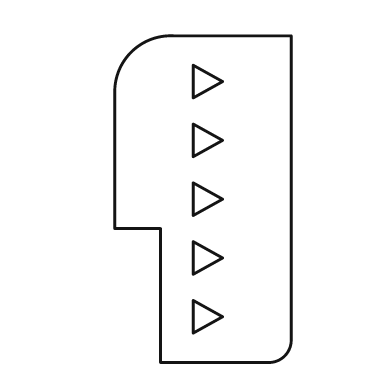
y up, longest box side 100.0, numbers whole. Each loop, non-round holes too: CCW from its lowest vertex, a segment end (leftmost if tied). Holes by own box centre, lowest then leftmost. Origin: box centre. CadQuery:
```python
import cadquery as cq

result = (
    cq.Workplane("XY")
    .moveTo(-13.0, -50.0)
    .lineTo(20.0, -50.0)
    .threePointArc((25.0, -48.0), (27.0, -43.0))
    .lineTo(27.0, 50.0)
    .lineTo(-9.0, 50.0)
    .threePointArc((-22.0, 45.0), (-27.0, 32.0))
    .lineTo(-27.0, -9.0)
    .lineTo(-13.0, -9.0)
    .close()
    .moveTo(-3.0, -41.0)
    .lineTo(6.0, -36.0)
    .lineTo(-3.0, -31.0)
    .close()
    .moveTo(-3.0, -23.0)
    .lineTo(6.0, -18.0)
    .lineTo(-3.0, -13.0)
    .close()
    .moveTo(-3.0, -5.0)
    .lineTo(6.0, 0.0)
    .lineTo(-3.0, 5.0)
    .close()
    .moveTo(-3.0, 13.0)
    .lineTo(6.0, 18.0)
    .lineTo(-3.0, 23.0)
    .close()
    .moveTo(-3.0, 31.0)
    .lineTo(6.0, 36.0)
    .lineTo(-3.0, 41.0)
    .close()
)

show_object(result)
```